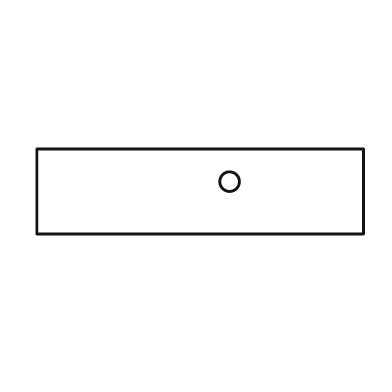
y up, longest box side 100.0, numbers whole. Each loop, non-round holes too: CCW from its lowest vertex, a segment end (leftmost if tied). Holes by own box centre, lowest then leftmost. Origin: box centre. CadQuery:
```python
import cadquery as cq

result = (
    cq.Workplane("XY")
    .moveTo(-50.0, -13.0)
    .lineTo(50.0, -13.0)
    .lineTo(50.0, 13.0)
    .lineTo(-50.0, 13.0)
    .close()
    .moveTo(9.0, 3.0)
    .circle(3.0)
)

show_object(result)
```